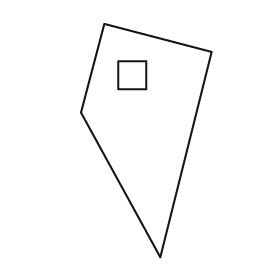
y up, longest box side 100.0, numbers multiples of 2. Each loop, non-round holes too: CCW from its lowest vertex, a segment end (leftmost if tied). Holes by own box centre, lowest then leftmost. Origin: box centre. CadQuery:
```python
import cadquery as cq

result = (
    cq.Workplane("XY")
    .moveTo(6.0, -50.0)
    .lineTo(28.0, 38.0)
    .lineTo(-18.0, 50.0)
    .lineTo(-28.0, 12.0)
    .close()
    .moveTo(-12.0, 22.0)
    .lineTo(0.0, 22.0)
    .lineTo(0.0, 34.0)
    .lineTo(-12.0, 34.0)
    .close()
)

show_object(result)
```